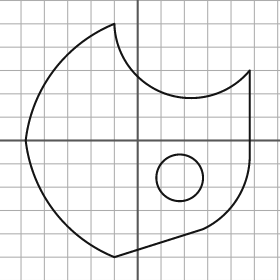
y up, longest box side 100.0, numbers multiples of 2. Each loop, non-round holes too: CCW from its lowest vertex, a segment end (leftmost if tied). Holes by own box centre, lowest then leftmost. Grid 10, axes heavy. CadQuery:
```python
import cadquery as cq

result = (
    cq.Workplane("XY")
    .moveTo(-10.0, -50.0)
    .lineTo(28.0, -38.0)
    .threePointArc((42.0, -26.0), (48.0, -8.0))
    .lineTo(48.0, 30.0)
    .threePointArc((12.0, 20.0), (-10.0, 50.0))
    .threePointArc((-36.0, 30.0), (-48.0, 0.0))
    .threePointArc((-36.0, -30.0), (-10.0, -50.0))
    .close()
    .moveTo(18.0, -16.0)
    .circle(10.0)
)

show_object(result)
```